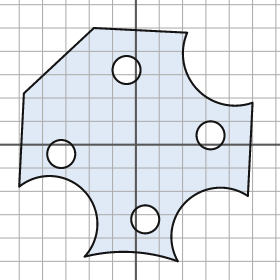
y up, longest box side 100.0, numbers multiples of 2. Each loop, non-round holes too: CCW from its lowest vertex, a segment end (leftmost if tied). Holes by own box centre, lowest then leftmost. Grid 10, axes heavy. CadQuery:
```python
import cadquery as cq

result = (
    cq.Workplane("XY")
    .moveTo(18.0, -50.0)
    .threePointArc((22.0, -24.0), (48.0, -22.0))
    .lineTo(50.0, 18.0)
    .threePointArc((26.0, 24.0), (22.0, 48.0))
    .lineTo(-18.0, 50.0)
    .lineTo(-48.0, 22.0)
    .lineTo(-50.0, -18.0)
    .threePointArc((-22.0, -20.0), (-22.0, -48.0))
    .threePointArc((-2.0, -46.0), (18.0, -50.0))
    .close()
    .moveTo(4.0, -32.0)
    .circle(6.0)
    .moveTo(-32.0, -4.0)
    .circle(6.0)
    .moveTo(32.0, 4.0)
    .circle(6.0)
    .moveTo(-4.0, 32.0)
    .circle(6.0)
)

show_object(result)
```